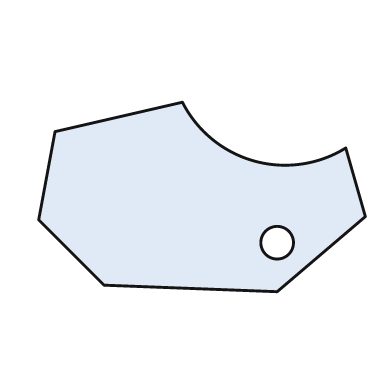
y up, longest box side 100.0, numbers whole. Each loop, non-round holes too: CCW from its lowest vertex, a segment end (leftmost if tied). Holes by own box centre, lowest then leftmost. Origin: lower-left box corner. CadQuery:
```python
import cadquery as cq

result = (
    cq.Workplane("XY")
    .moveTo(73.0, 0.0)
    .lineTo(100.0, 23.0)
    .lineTo(94.0, 44.0)
    .threePointArc((66.0, 40.0), (44.0, 58.0))
    .lineTo(5.0, 49.0)
    .lineTo(0.0, 22.0)
    .lineTo(20.0, 2.0)
    .close()
    .moveTo(73.0, 15.0)
    .circle(5.0)
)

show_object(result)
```